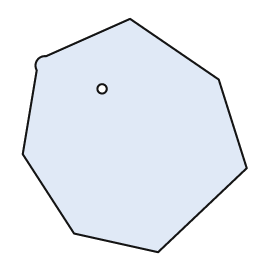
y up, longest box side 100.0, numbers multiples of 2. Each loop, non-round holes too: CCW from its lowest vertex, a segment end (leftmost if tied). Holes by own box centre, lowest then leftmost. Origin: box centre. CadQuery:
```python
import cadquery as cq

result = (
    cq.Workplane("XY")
    .moveTo(10.0, -50.0)
    .lineTo(48.0, -14.0)
    .lineTo(36.0, 24.0)
    .lineTo(-2.0, 50.0)
    .lineTo(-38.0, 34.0)
    .threePointArc((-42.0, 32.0), (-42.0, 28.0))
    .lineTo(-48.0, -8.0)
    .lineTo(-26.0, -42.0)
    .close()
    .moveTo(-14.0, 20.0)
    .circle(2.0)
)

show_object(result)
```